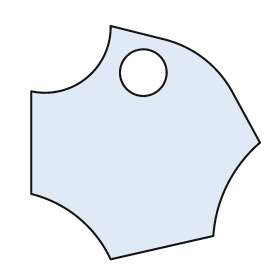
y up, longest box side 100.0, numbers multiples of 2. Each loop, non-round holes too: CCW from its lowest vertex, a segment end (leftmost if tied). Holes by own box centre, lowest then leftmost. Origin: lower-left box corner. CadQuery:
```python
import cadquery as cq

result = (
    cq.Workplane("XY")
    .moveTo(34.0, 0.0)
    .lineTo(78.0, 10.0)
    .threePointArc((84.0, 32.0), (98.0, 50.0))
    .lineTo(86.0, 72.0)
    .threePointArc((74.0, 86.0), (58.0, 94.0))
    .lineTo(34.0, 100.0)
    .threePointArc((24.0, 78.0), (0.0, 72.0))
    .lineTo(0.0, 28.0)
    .threePointArc((20.0, 18.0), (34.0, 0.0))
    .close()
    .moveTo(48.0, 80.0)
    .circle(10.0)
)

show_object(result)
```